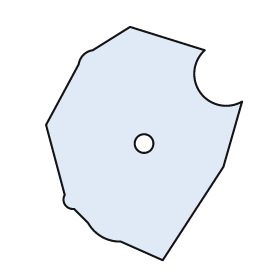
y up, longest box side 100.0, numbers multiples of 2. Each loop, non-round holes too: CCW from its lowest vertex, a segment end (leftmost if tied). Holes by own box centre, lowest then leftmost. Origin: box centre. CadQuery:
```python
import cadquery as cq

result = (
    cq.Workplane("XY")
    .moveTo(8.0, -50.0)
    .lineTo(34.0, -10.0)
    .lineTo(42.0, 18.0)
    .threePointArc((24.0, 22.0), (26.0, 40.0))
    .lineTo(-6.0, 50.0)
    .lineTo(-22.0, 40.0)
    .threePointArc((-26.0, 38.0), (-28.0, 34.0))
    .lineTo(-42.0, 8.0)
    .lineTo(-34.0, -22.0)
    .threePointArc((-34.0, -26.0), (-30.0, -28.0))
    .lineTo(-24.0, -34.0)
    .threePointArc((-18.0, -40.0), (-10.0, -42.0))
    .close()
    .moveTo(0.0, 0.0)
    .circle(4.0)
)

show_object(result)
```